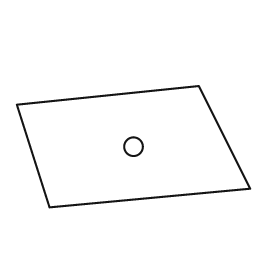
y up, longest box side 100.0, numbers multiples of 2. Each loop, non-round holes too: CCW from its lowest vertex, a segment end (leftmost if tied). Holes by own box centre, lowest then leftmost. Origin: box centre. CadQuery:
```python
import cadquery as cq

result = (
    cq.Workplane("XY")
    .moveTo(-36.0, -26.0)
    .lineTo(50.0, -18.0)
    .lineTo(28.0, 26.0)
    .lineTo(-50.0, 18.0)
    .close()
    .moveTo(0.0, 0.0)
    .circle(4.0)
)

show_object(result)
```